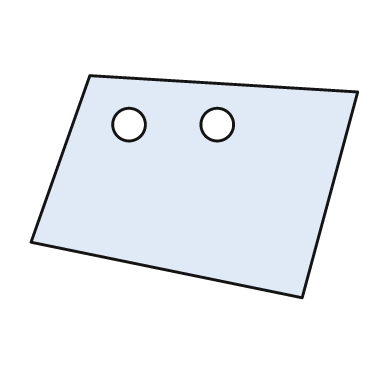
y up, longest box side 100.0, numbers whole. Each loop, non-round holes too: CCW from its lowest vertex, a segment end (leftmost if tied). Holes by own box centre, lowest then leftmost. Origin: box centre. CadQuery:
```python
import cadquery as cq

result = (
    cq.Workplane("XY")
    .moveTo(33.0, -34.0)
    .lineTo(50.0, 29.0)
    .lineTo(-32.0, 34.0)
    .lineTo(-50.0, -17.0)
    .close()
    .moveTo(-20.0, 19.0)
    .circle(5.0)
    .moveTo(7.0, 19.0)
    .circle(5.0)
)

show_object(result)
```